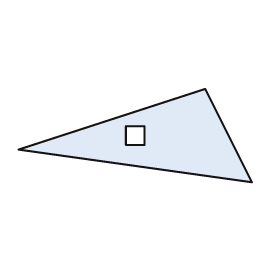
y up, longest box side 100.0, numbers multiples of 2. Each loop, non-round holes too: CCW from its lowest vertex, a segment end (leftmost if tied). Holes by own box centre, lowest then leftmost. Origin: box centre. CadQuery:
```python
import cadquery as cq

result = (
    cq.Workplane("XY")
    .moveTo(50.0, -20.0)
    .lineTo(30.0, 20.0)
    .lineTo(-50.0, -6.0)
    .close()
    .moveTo(-4.0, -4.0)
    .lineTo(4.0, -4.0)
    .lineTo(4.0, 4.0)
    .lineTo(-4.0, 4.0)
    .close()
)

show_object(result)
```